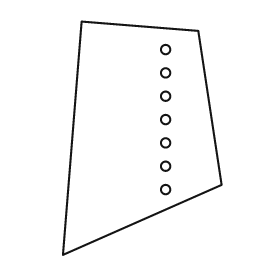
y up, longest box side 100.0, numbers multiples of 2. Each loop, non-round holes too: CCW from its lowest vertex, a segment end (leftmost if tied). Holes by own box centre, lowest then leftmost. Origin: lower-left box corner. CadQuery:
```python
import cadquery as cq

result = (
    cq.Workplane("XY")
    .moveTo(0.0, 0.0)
    .lineTo(68.0, 30.0)
    .lineTo(58.0, 96.0)
    .lineTo(8.0, 100.0)
    .close()
    .moveTo(44.0, 28.0)
    .circle(2.0)
    .moveTo(44.0, 38.0)
    .circle(2.0)
    .moveTo(44.0, 48.0)
    .circle(2.0)
    .moveTo(44.0, 58.0)
    .circle(2.0)
    .moveTo(44.0, 68.0)
    .circle(2.0)
    .moveTo(44.0, 78.0)
    .circle(2.0)
    .moveTo(44.0, 88.0)
    .circle(2.0)
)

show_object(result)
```